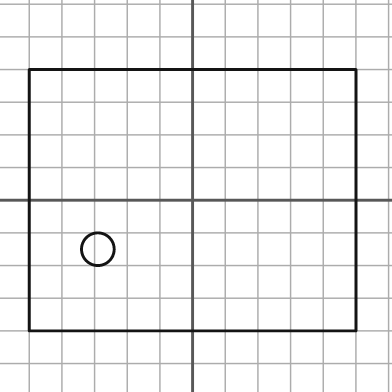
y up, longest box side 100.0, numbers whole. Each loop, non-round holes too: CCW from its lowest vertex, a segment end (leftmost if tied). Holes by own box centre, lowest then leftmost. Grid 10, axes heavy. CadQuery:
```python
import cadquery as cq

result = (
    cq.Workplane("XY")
    .moveTo(-50.0, -40.0)
    .lineTo(50.0, -40.0)
    .lineTo(50.0, 40.0)
    .lineTo(-50.0, 40.0)
    .close()
    .moveTo(-29.0, -15.0)
    .circle(5.0)
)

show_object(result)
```